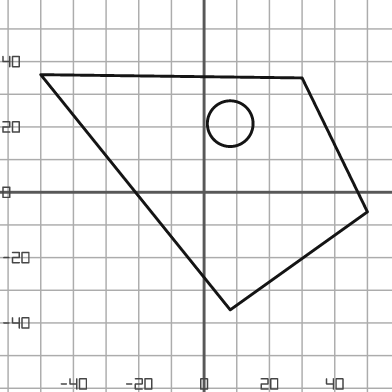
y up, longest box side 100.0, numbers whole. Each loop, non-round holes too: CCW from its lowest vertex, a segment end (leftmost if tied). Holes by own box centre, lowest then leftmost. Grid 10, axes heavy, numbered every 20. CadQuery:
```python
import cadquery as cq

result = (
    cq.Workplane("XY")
    .moveTo(8.0, -36.0)
    .lineTo(50.0, -6.0)
    .lineTo(30.0, 35.0)
    .lineTo(-50.0, 36.0)
    .close()
    .moveTo(8.0, 21.0)
    .circle(7.0)
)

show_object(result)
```